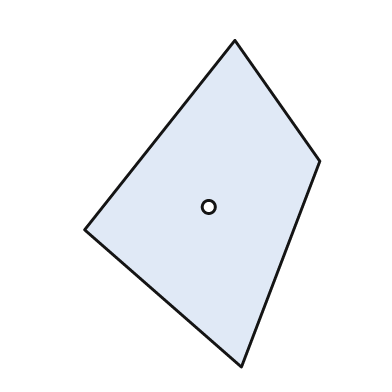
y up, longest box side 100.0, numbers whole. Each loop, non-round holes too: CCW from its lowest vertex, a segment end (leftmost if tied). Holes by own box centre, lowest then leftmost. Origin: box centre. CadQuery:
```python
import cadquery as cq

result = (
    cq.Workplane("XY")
    .moveTo(12.0, -50.0)
    .lineTo(36.0, 13.0)
    .lineTo(10.0, 50.0)
    .lineTo(-36.0, -8.0)
    .close()
    .moveTo(2.0, -1.0)
    .circle(2.0)
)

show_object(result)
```